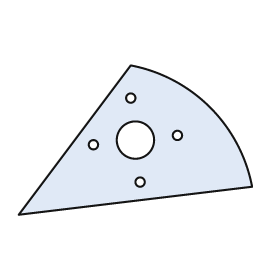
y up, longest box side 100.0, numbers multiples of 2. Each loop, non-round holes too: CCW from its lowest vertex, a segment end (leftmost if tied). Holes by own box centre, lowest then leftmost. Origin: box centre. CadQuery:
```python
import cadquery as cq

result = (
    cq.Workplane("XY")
    .moveTo(-50.0, -32.0)
    .lineTo(50.0, -20.0)
    .threePointArc((32.0, 14.0), (-2.0, 32.0))
    .close()
    .moveTo(2.0, -18.0)
    .circle(2.0)
    .moveTo(-18.0, -2.0)
    .circle(2.0)
    .moveTo(0.0, 0.0)
    .circle(8.0)
    .moveTo(18.0, 2.0)
    .circle(2.0)
    .moveTo(-2.0, 18.0)
    .circle(2.0)
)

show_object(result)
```